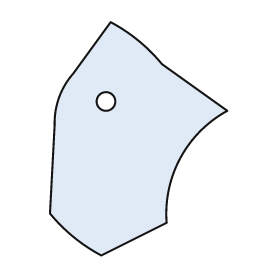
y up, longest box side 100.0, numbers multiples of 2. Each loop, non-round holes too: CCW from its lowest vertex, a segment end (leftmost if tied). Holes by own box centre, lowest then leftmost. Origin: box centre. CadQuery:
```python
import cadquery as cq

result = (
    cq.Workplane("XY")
    .moveTo(-16.0, -50.0)
    .lineTo(12.0, -36.0)
    .threePointArc((18.0, -8.0), (38.0, 12.0))
    .lineTo(10.0, 32.0)
    .threePointArc((0.0, 42.0), (-12.0, 50.0))
    .lineTo(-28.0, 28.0)
    .threePointArc((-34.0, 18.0), (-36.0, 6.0))
    .lineTo(-38.0, -32.0)
    .threePointArc((-28.0, -42.0), (-16.0, -50.0))
    .close()
    .moveTo(-14.0, 16.0)
    .circle(4.0)
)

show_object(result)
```